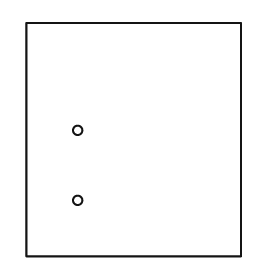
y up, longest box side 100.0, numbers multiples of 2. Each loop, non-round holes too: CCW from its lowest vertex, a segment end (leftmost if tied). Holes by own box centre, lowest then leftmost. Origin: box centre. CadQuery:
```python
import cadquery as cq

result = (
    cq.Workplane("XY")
    .moveTo(-46.0, -50.0)
    .lineTo(46.0, -50.0)
    .lineTo(46.0, 50.0)
    .lineTo(-46.0, 50.0)
    .close()
    .moveTo(-24.0, -26.0)
    .circle(2.0)
    .moveTo(-24.0, 4.0)
    .circle(2.0)
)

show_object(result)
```